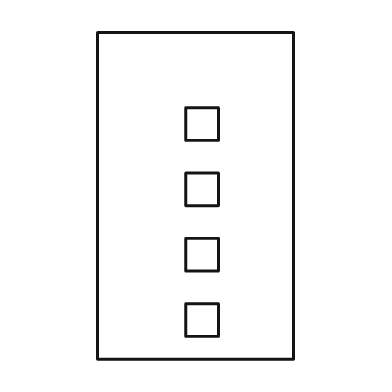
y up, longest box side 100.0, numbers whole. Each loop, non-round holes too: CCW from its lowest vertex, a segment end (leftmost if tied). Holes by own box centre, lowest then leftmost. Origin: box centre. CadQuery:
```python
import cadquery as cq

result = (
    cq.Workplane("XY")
    .moveTo(-30.0, -50.0)
    .lineTo(30.0, -50.0)
    .lineTo(30.0, 50.0)
    .lineTo(-30.0, 50.0)
    .close()
    .moveTo(-3.0, -43.0)
    .lineTo(7.0, -43.0)
    .lineTo(7.0, -33.0)
    .lineTo(-3.0, -33.0)
    .close()
    .moveTo(-3.0, -23.0)
    .lineTo(7.0, -23.0)
    .lineTo(7.0, -13.0)
    .lineTo(-3.0, -13.0)
    .close()
    .moveTo(-3.0, -3.0)
    .lineTo(7.0, -3.0)
    .lineTo(7.0, 7.0)
    .lineTo(-3.0, 7.0)
    .close()
    .moveTo(-3.0, 17.0)
    .lineTo(7.0, 17.0)
    .lineTo(7.0, 27.0)
    .lineTo(-3.0, 27.0)
    .close()
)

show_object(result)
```